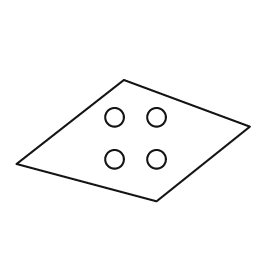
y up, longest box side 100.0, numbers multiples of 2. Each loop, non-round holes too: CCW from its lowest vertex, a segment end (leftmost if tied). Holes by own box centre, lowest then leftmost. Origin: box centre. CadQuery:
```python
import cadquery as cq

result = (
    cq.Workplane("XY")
    .moveTo(10.0, -26.0)
    .lineTo(50.0, 6.0)
    .lineTo(-4.0, 26.0)
    .lineTo(-50.0, -10.0)
    .close()
    .moveTo(-8.0, -8.0)
    .circle(4.0)
    .moveTo(10.0, -8.0)
    .circle(4.0)
    .moveTo(-8.0, 10.0)
    .circle(4.0)
    .moveTo(10.0, 10.0)
    .circle(4.0)
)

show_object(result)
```